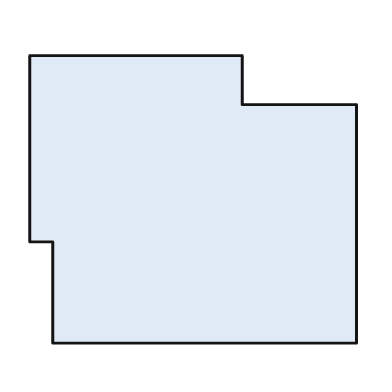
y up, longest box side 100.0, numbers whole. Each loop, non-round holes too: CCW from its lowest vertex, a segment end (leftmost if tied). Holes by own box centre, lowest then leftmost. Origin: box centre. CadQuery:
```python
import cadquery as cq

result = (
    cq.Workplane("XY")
    .moveTo(-43.0, -44.0)
    .lineTo(50.0, -44.0)
    .lineTo(50.0, 29.0)
    .lineTo(15.0, 29.0)
    .lineTo(15.0, 44.0)
    .lineTo(-50.0, 44.0)
    .lineTo(-50.0, -13.0)
    .lineTo(-43.0, -13.0)
    .close()
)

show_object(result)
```